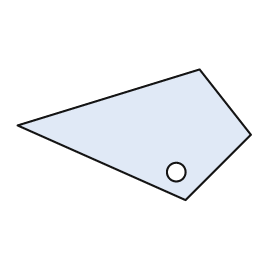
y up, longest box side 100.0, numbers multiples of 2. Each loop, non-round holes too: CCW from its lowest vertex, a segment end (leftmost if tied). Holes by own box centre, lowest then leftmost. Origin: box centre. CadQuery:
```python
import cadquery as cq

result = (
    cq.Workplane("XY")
    .moveTo(22.0, -28.0)
    .lineTo(50.0, 0.0)
    .lineTo(28.0, 28.0)
    .lineTo(-50.0, 4.0)
    .close()
    .moveTo(18.0, -16.0)
    .circle(4.0)
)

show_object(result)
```